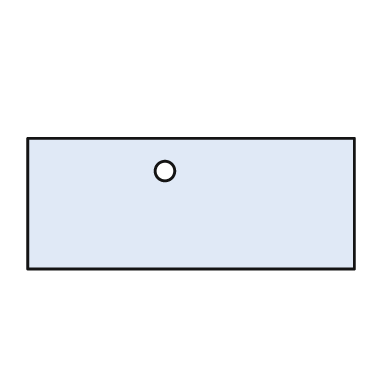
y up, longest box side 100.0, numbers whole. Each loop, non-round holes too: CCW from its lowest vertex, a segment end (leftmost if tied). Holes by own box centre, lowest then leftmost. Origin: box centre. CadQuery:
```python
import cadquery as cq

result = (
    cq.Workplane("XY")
    .moveTo(-50.0, -20.0)
    .lineTo(50.0, -20.0)
    .lineTo(50.0, 20.0)
    .lineTo(-50.0, 20.0)
    .close()
    .moveTo(-8.0, 10.0)
    .circle(3.0)
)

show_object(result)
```